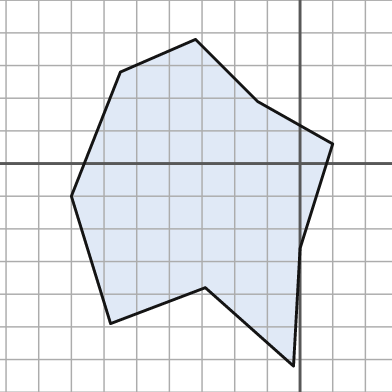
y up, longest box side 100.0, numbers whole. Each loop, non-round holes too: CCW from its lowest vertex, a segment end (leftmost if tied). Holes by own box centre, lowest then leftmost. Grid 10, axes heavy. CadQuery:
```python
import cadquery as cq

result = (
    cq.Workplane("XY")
    .moveTo(-2.0, -62.0)
    .lineTo(0.0, -26.0)
    .lineTo(10.0, 6.0)
    .lineTo(-13.0, 19.0)
    .lineTo(-32.0, 38.0)
    .lineTo(-55.0, 28.0)
    .lineTo(-70.0, -10.0)
    .lineTo(-58.0, -49.0)
    .lineTo(-29.0, -38.0)
    .close()
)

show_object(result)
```